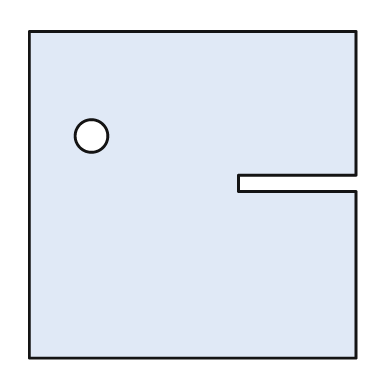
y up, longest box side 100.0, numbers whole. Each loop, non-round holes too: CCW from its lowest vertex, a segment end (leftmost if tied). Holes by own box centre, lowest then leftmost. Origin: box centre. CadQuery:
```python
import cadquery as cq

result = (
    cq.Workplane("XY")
    .moveTo(-50.0, -50.0)
    .lineTo(50.0, -50.0)
    .lineTo(50.0, 1.0)
    .lineTo(14.0, 1.0)
    .lineTo(14.0, 6.0)
    .lineTo(50.0, 6.0)
    .lineTo(50.0, 50.0)
    .lineTo(-50.0, 50.0)
    .close()
    .moveTo(-31.0, 18.0)
    .circle(5.0)
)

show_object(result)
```